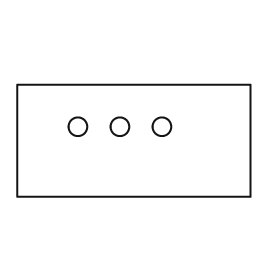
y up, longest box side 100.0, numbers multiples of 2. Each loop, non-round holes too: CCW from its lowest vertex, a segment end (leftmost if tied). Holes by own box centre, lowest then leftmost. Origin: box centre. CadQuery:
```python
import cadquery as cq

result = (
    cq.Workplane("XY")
    .moveTo(-50.0, -24.0)
    .lineTo(50.0, -24.0)
    .lineTo(50.0, 24.0)
    .lineTo(-50.0, 24.0)
    .close()
    .moveTo(-24.0, 6.0)
    .circle(4.0)
    .moveTo(-6.0, 6.0)
    .circle(4.0)
    .moveTo(12.0, 6.0)
    .circle(4.0)
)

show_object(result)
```